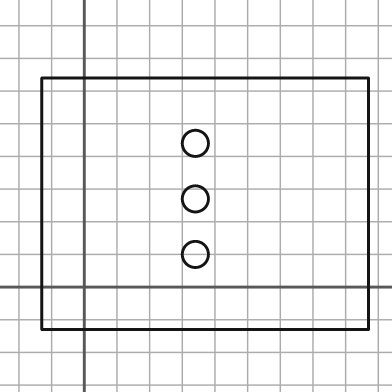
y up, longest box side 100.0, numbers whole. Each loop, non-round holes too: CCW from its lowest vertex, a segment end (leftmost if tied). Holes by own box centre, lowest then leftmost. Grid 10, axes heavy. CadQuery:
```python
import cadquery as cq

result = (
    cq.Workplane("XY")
    .moveTo(-13.0, -13.0)
    .lineTo(87.0, -13.0)
    .lineTo(87.0, 64.0)
    .lineTo(-13.0, 64.0)
    .close()
    .moveTo(34.0, 10.0)
    .circle(4.0)
    .moveTo(34.0, 27.0)
    .circle(4.0)
    .moveTo(34.0, 44.0)
    .circle(4.0)
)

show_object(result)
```